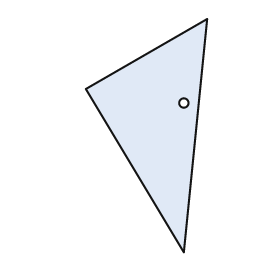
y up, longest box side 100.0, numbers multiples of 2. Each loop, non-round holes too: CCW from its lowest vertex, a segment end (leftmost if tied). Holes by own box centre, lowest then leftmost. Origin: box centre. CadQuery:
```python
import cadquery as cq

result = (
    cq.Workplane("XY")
    .moveTo(16.0, -50.0)
    .lineTo(26.0, 50.0)
    .lineTo(-26.0, 20.0)
    .close()
    .moveTo(16.0, 14.0)
    .circle(2.0)
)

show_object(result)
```